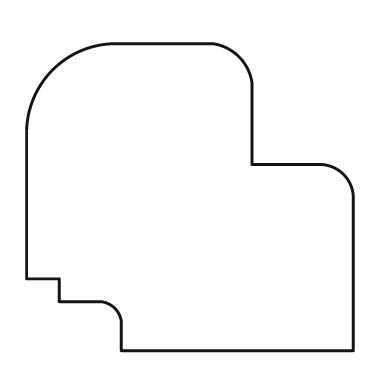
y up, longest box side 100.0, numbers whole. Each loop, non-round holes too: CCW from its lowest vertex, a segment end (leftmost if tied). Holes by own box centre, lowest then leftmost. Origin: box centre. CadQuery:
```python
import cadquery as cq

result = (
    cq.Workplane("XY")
    .moveTo(-21.0, -47.0)
    .lineTo(50.0, -47.0)
    .lineTo(50.0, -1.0)
    .threePointArc((47.0, 7.0), (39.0, 10.0))
    .lineTo(19.0, 10.0)
    .lineTo(19.0, 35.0)
    .threePointArc((15.0, 43.0), (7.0, 47.0))
    .lineTo(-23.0, 47.0)
    .threePointArc((-42.0, 39.0), (-50.0, 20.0))
    .lineTo(-50.0, -25.0)
    .lineTo(-40.0, -25.0)
    .lineTo(-40.0, -32.0)
    .lineTo(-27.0, -32.0)
    .threePointArc((-23.0, -34.0), (-21.0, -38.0))
    .close()
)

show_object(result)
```